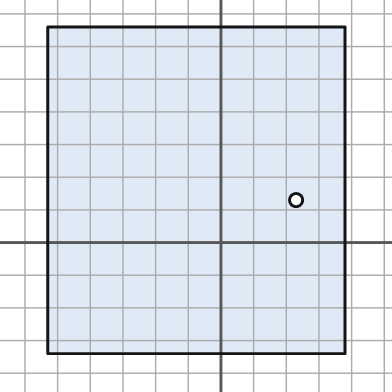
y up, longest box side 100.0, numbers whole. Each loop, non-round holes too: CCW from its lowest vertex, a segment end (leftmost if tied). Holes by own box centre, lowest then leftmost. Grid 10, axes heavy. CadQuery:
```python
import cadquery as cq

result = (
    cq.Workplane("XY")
    .moveTo(-53.0, -34.0)
    .lineTo(38.0, -34.0)
    .lineTo(38.0, 66.0)
    .lineTo(-53.0, 66.0)
    .close()
    .moveTo(23.0, 13.0)
    .circle(2.0)
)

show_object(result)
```